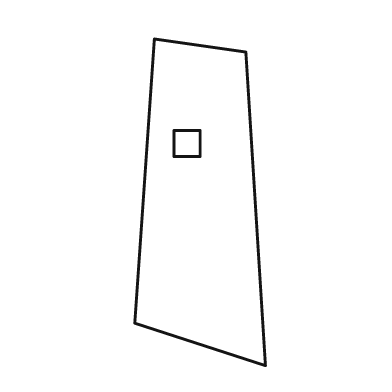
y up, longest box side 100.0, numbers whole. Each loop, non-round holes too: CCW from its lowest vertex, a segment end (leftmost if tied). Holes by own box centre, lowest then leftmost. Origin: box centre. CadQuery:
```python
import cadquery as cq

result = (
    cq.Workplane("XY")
    .moveTo(20.0, -50.0)
    .lineTo(14.0, 46.0)
    .lineTo(-14.0, 50.0)
    .lineTo(-20.0, -37.0)
    .close()
    .moveTo(-8.0, 14.0)
    .lineTo(0.0, 14.0)
    .lineTo(0.0, 22.0)
    .lineTo(-8.0, 22.0)
    .close()
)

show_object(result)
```